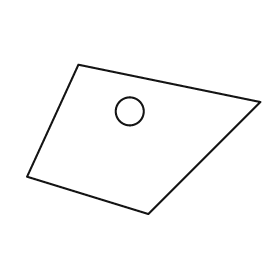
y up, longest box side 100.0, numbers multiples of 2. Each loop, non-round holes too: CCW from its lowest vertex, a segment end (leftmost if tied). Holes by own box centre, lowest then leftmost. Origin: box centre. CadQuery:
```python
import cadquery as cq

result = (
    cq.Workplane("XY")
    .moveTo(2.0, -32.0)
    .lineTo(50.0, 16.0)
    .lineTo(-28.0, 32.0)
    .lineTo(-50.0, -16.0)
    .close()
    .moveTo(-6.0, 12.0)
    .circle(6.0)
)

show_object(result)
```